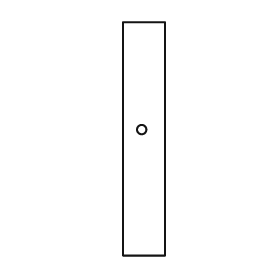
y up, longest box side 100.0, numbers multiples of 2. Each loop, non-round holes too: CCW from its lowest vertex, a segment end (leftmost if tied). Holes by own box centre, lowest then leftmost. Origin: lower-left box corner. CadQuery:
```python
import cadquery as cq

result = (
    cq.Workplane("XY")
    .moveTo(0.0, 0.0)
    .lineTo(18.0, 0.0)
    .lineTo(18.0, 100.0)
    .lineTo(0.0, 100.0)
    .close()
    .moveTo(8.0, 54.0)
    .circle(2.0)
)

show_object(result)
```